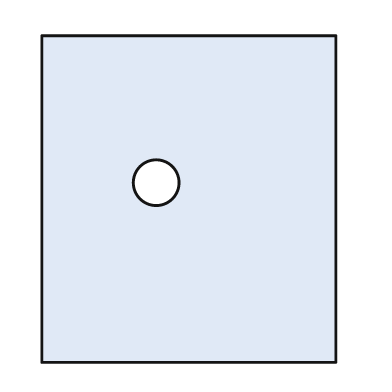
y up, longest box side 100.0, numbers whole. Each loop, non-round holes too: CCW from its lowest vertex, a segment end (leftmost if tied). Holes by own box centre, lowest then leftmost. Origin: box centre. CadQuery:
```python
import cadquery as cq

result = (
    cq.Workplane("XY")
    .moveTo(-45.0, -50.0)
    .lineTo(45.0, -50.0)
    .lineTo(45.0, 50.0)
    .lineTo(-45.0, 50.0)
    .close()
    .moveTo(-10.0, 5.0)
    .circle(7.0)
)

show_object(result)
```